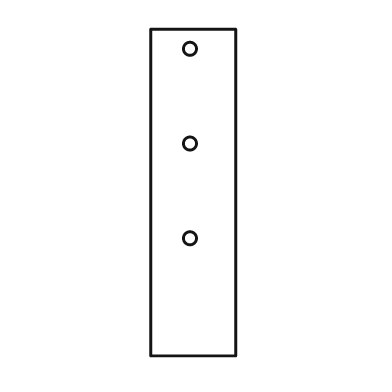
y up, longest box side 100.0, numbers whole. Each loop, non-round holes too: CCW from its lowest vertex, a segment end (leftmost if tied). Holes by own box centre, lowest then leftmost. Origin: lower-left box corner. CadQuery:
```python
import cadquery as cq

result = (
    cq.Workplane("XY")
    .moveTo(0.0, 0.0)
    .lineTo(26.0, 0.0)
    .lineTo(26.0, 100.0)
    .lineTo(0.0, 100.0)
    .close()
    .moveTo(12.0, 36.0)
    .circle(2.0)
    .moveTo(12.0, 65.0)
    .circle(2.0)
    .moveTo(12.0, 94.0)
    .circle(2.0)
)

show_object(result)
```